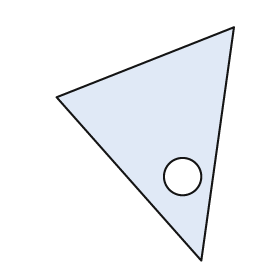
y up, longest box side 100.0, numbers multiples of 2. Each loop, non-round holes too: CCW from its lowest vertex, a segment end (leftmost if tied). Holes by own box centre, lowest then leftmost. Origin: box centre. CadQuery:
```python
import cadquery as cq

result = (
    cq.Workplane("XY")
    .moveTo(24.0, -50.0)
    .lineTo(38.0, 50.0)
    .lineTo(-38.0, 20.0)
    .close()
    .moveTo(16.0, -14.0)
    .circle(8.0)
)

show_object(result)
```